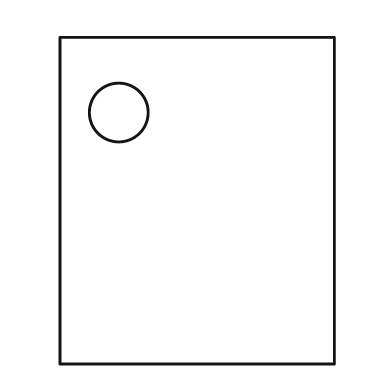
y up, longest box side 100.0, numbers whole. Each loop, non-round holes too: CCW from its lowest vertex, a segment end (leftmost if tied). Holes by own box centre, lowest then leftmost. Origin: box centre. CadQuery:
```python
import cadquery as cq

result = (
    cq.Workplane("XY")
    .moveTo(-42.0, -50.0)
    .lineTo(42.0, -50.0)
    .lineTo(42.0, 50.0)
    .lineTo(-42.0, 50.0)
    .close()
    .moveTo(-24.0, 27.0)
    .circle(9.0)
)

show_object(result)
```